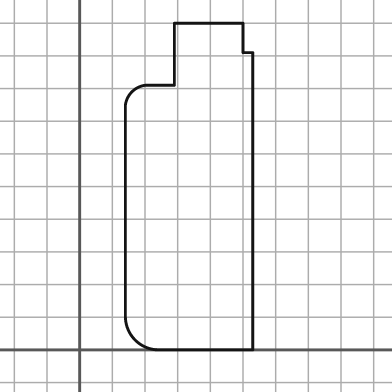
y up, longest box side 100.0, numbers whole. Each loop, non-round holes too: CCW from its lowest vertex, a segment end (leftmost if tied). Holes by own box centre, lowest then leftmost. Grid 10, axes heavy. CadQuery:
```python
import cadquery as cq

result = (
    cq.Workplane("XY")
    .moveTo(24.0, 0.0)
    .lineTo(53.0, 0.0)
    .lineTo(53.0, 91.0)
    .lineTo(50.0, 91.0)
    .lineTo(50.0, 100.0)
    .lineTo(29.0, 100.0)
    .lineTo(29.0, 81.0)
    .lineTo(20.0, 81.0)
    .threePointArc((16.0, 79.0), (14.0, 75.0))
    .lineTo(14.0, 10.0)
    .threePointArc((17.0, 3.0), (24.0, 0.0))
    .close()
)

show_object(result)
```